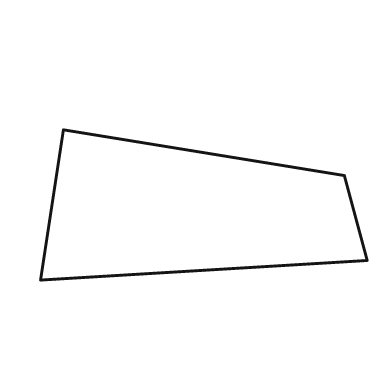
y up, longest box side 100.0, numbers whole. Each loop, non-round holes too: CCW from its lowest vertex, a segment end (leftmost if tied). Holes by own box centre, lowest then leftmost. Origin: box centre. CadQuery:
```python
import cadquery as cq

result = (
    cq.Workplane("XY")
    .moveTo(-50.0, -23.0)
    .lineTo(50.0, -17.0)
    .lineTo(43.0, 9.0)
    .lineTo(-43.0, 23.0)
    .close()
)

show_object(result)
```